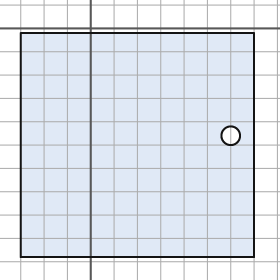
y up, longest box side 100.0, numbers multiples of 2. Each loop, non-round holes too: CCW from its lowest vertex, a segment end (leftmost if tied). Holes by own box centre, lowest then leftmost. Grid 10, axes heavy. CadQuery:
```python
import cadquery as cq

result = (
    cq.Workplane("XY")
    .moveTo(-30.0, -98.0)
    .lineTo(70.0, -98.0)
    .lineTo(70.0, -2.0)
    .lineTo(-30.0, -2.0)
    .close()
    .moveTo(60.0, -46.0)
    .circle(4.0)
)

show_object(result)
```